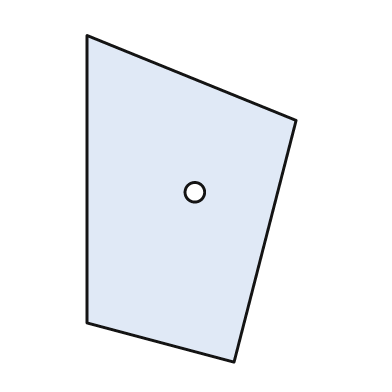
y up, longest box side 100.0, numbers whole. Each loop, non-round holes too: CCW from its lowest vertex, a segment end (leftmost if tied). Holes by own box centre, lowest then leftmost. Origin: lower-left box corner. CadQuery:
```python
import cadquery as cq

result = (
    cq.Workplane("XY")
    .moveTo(45.0, 0.0)
    .lineTo(64.0, 74.0)
    .lineTo(0.0, 100.0)
    .lineTo(0.0, 12.0)
    .close()
    .moveTo(33.0, 52.0)
    .circle(3.0)
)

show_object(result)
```